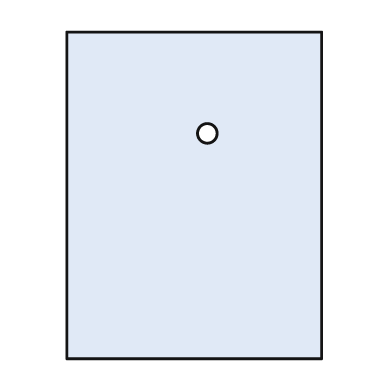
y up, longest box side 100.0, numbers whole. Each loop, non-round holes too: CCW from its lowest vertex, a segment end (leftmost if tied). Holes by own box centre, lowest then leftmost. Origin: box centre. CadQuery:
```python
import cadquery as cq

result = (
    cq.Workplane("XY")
    .moveTo(-39.0, -50.0)
    .lineTo(39.0, -50.0)
    .lineTo(39.0, 50.0)
    .lineTo(-39.0, 50.0)
    .close()
    .moveTo(4.0, 19.0)
    .circle(3.0)
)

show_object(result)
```